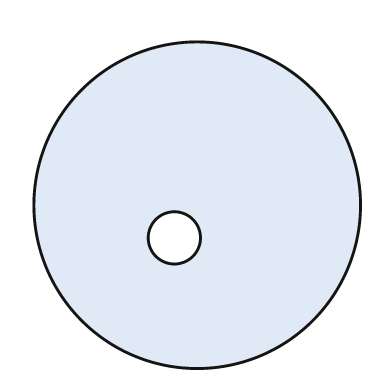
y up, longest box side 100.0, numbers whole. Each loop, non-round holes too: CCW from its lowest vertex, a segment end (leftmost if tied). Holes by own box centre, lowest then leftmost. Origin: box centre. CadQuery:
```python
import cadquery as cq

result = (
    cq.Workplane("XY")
    .moveTo(0.0, 0.0)
    .circle(50.0)
    .moveTo(-7.0, -10.0)
    .circle(8.0)
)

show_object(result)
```